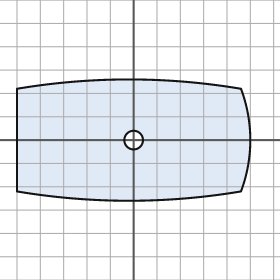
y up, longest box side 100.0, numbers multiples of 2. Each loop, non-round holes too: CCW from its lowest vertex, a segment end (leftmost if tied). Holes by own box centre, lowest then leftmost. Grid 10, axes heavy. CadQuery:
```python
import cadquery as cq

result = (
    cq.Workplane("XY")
    .moveTo(-50.0, -22.0)
    .threePointArc((-2.0, -26.0), (46.0, -22.0))
    .threePointArc((50.0, 0.0), (46.0, 22.0))
    .threePointArc((-2.0, 26.0), (-50.0, 22.0))
    .close()
    .moveTo(0.0, 0.0)
    .circle(4.0)
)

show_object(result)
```